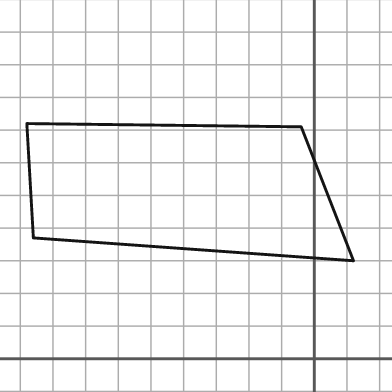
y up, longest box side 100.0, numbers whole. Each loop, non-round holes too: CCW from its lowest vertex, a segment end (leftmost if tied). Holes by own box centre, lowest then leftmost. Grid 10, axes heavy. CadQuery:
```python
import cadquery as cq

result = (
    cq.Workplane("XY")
    .moveTo(12.0, 30.0)
    .lineTo(-4.0, 71.0)
    .lineTo(-88.0, 72.0)
    .lineTo(-86.0, 37.0)
    .close()
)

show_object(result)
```